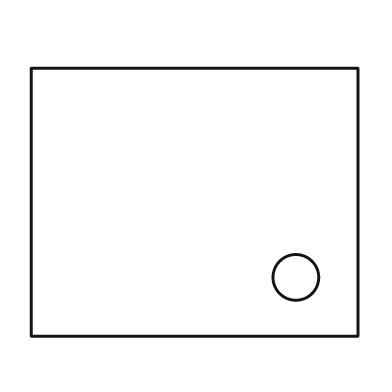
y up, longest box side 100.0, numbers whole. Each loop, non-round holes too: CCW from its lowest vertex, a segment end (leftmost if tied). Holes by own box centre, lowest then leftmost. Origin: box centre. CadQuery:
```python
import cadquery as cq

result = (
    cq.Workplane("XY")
    .moveTo(-50.0, -41.0)
    .lineTo(50.0, -41.0)
    .lineTo(50.0, 41.0)
    .lineTo(-50.0, 41.0)
    .close()
    .moveTo(31.0, -23.0)
    .circle(7.0)
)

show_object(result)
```